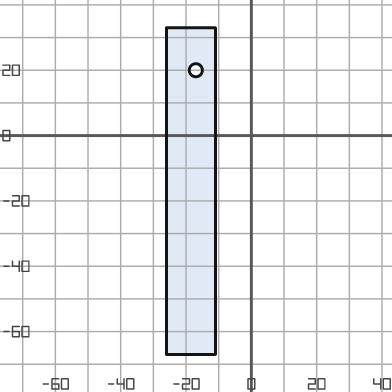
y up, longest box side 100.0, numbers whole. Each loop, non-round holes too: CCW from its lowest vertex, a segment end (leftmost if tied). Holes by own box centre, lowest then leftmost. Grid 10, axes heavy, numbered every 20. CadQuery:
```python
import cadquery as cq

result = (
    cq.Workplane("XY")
    .moveTo(-26.0, -67.0)
    .lineTo(-11.0, -67.0)
    .lineTo(-11.0, 33.0)
    .lineTo(-26.0, 33.0)
    .close()
    .moveTo(-17.0, 20.0)
    .circle(2.0)
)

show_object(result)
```